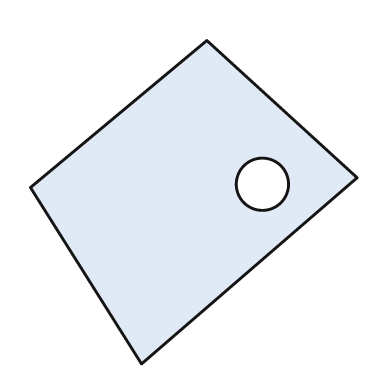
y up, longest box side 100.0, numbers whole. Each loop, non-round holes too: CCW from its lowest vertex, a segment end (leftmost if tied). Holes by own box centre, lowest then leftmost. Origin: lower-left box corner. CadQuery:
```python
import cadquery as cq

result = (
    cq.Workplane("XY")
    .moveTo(34.0, 0.0)
    .lineTo(100.0, 57.0)
    .lineTo(54.0, 99.0)
    .lineTo(0.0, 54.0)
    .close()
    .moveTo(71.0, 55.0)
    .circle(8.0)
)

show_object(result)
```